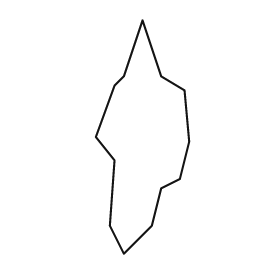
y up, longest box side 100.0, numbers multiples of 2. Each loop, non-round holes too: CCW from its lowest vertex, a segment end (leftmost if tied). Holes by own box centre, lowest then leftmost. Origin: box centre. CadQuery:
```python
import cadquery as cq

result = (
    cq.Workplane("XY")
    .moveTo(-8.0, -50.0)
    .lineTo(4.0, -38.0)
    .lineTo(8.0, -22.0)
    .lineTo(16.0, -18.0)
    .lineTo(20.0, -2.0)
    .lineTo(18.0, 20.0)
    .lineTo(8.0, 26.0)
    .lineTo(0.0, 50.0)
    .lineTo(-8.0, 26.0)
    .lineTo(-12.0, 22.0)
    .lineTo(-20.0, 0.0)
    .lineTo(-12.0, -10.0)
    .lineTo(-14.0, -38.0)
    .close()
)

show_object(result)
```